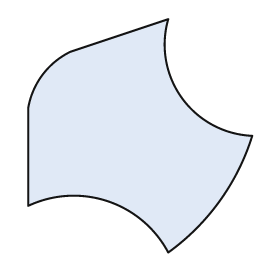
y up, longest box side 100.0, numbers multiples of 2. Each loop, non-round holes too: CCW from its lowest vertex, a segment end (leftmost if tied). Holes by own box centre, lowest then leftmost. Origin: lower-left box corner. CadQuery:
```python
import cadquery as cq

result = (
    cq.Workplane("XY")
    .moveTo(60.0, 0.0)
    .threePointArc((82.0, 22.0), (96.0, 50.0))
    .threePointArc((66.0, 66.0), (60.0, 100.0))
    .lineTo(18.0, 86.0)
    .threePointArc((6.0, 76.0), (0.0, 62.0))
    .lineTo(0.0, 20.0)
    .threePointArc((34.0, 22.0), (60.0, 0.0))
    .close()
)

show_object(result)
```